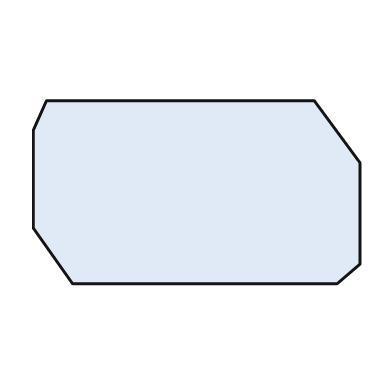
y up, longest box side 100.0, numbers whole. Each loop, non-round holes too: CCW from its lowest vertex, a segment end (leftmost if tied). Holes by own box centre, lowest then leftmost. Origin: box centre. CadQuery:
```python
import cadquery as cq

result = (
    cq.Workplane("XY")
    .moveTo(-38.0, -28.0)
    .lineTo(43.0, -28.0)
    .lineTo(50.0, -22.0)
    .lineTo(50.0, 9.0)
    .lineTo(36.0, 28.0)
    .lineTo(-46.0, 28.0)
    .lineTo(-50.0, 19.0)
    .lineTo(-50.0, -11.0)
    .close()
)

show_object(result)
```